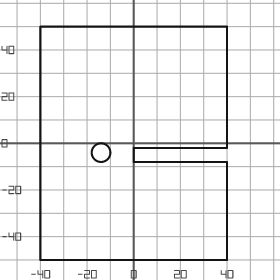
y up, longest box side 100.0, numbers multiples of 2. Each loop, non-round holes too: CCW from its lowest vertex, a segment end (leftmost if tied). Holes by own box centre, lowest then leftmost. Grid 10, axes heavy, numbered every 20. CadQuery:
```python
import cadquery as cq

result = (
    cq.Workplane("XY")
    .moveTo(-40.0, -50.0)
    .lineTo(40.0, -50.0)
    .lineTo(40.0, -8.0)
    .lineTo(0.0, -8.0)
    .lineTo(0.0, -2.0)
    .lineTo(40.0, -2.0)
    .lineTo(40.0, 50.0)
    .lineTo(-40.0, 50.0)
    .close()
    .moveTo(-14.0, -4.0)
    .circle(4.0)
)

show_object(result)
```